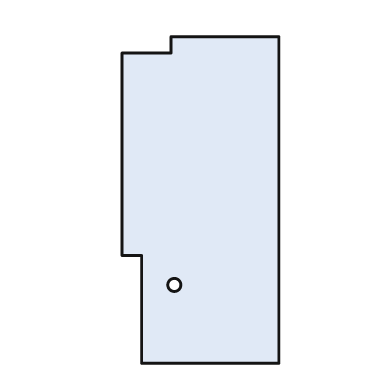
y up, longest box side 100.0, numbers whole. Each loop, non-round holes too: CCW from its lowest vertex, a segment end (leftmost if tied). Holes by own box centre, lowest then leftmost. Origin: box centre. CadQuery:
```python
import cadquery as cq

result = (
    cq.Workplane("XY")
    .moveTo(-18.0, -50.0)
    .lineTo(24.0, -50.0)
    .lineTo(24.0, 50.0)
    .lineTo(-9.0, 50.0)
    .lineTo(-9.0, 45.0)
    .lineTo(-24.0, 45.0)
    .lineTo(-24.0, -17.0)
    .lineTo(-18.0, -17.0)
    .close()
    .moveTo(-8.0, -26.0)
    .circle(2.0)
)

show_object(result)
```